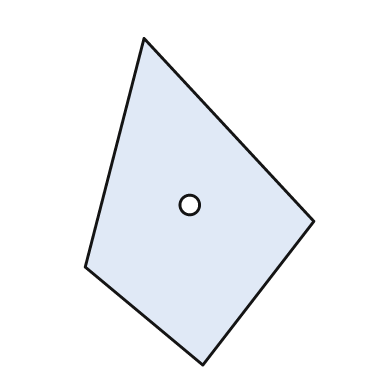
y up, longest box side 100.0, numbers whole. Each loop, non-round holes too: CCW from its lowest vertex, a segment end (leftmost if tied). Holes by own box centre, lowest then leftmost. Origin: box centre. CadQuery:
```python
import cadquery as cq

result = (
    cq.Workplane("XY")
    .moveTo(1.0, -50.0)
    .lineTo(35.0, -6.0)
    .lineTo(-17.0, 50.0)
    .lineTo(-35.0, -20.0)
    .close()
    .moveTo(-3.0, -1.0)
    .circle(3.0)
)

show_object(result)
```